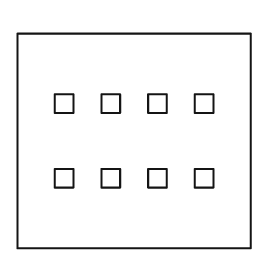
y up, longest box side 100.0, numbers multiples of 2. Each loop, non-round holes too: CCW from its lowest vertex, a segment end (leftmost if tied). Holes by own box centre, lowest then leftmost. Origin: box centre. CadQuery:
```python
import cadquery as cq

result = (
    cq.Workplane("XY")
    .moveTo(-50.0, -46.0)
    .lineTo(50.0, -46.0)
    .lineTo(50.0, 46.0)
    .lineTo(-50.0, 46.0)
    .close()
    .moveTo(-34.0, -20.0)
    .lineTo(-26.0, -20.0)
    .lineTo(-26.0, -12.0)
    .lineTo(-34.0, -12.0)
    .close()
    .moveTo(-14.0, -20.0)
    .lineTo(-6.0, -20.0)
    .lineTo(-6.0, -12.0)
    .lineTo(-14.0, -12.0)
    .close()
    .moveTo(6.0, -20.0)
    .lineTo(14.0, -20.0)
    .lineTo(14.0, -12.0)
    .lineTo(6.0, -12.0)
    .close()
    .moveTo(26.0, -20.0)
    .lineTo(34.0, -20.0)
    .lineTo(34.0, -12.0)
    .lineTo(26.0, -12.0)
    .close()
    .moveTo(-34.0, 12.0)
    .lineTo(-26.0, 12.0)
    .lineTo(-26.0, 20.0)
    .lineTo(-34.0, 20.0)
    .close()
    .moveTo(-14.0, 12.0)
    .lineTo(-6.0, 12.0)
    .lineTo(-6.0, 20.0)
    .lineTo(-14.0, 20.0)
    .close()
    .moveTo(6.0, 12.0)
    .lineTo(14.0, 12.0)
    .lineTo(14.0, 20.0)
    .lineTo(6.0, 20.0)
    .close()
    .moveTo(26.0, 12.0)
    .lineTo(34.0, 12.0)
    .lineTo(34.0, 20.0)
    .lineTo(26.0, 20.0)
    .close()
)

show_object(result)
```